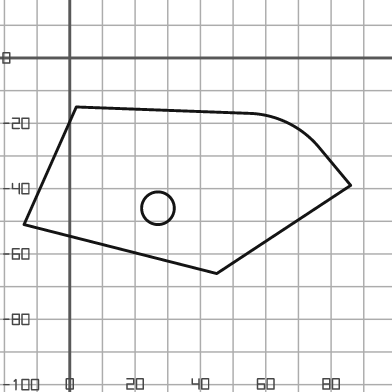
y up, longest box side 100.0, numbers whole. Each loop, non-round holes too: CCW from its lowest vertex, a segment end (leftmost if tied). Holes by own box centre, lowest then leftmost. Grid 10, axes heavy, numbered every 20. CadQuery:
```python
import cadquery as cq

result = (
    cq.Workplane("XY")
    .moveTo(45.0, -66.0)
    .lineTo(86.0, -39.0)
    .lineTo(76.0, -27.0)
    .threePointArc((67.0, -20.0), (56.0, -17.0))
    .lineTo(2.0, -15.0)
    .lineTo(-14.0, -51.0)
    .close()
    .moveTo(27.0, -46.0)
    .circle(5.0)
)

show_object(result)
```